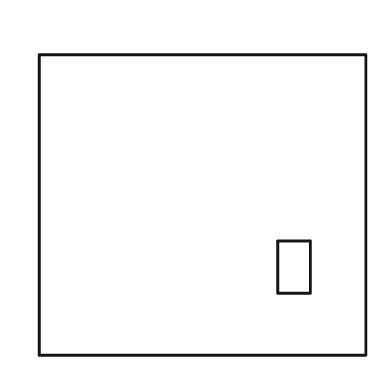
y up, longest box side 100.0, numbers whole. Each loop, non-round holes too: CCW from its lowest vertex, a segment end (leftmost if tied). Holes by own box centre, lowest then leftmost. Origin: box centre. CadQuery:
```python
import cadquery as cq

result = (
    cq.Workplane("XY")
    .moveTo(-50.0, -46.0)
    .lineTo(50.0, -46.0)
    .lineTo(50.0, 46.0)
    .lineTo(-50.0, 46.0)
    .close()
    .moveTo(23.0, -27.0)
    .lineTo(33.0, -27.0)
    .lineTo(33.0, -11.0)
    .lineTo(23.0, -11.0)
    .close()
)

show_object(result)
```